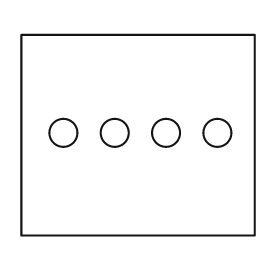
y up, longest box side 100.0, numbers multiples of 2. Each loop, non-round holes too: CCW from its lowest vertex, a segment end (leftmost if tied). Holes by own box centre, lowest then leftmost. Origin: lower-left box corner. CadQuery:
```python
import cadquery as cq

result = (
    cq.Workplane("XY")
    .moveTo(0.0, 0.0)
    .lineTo(100.0, 0.0)
    .lineTo(100.0, 86.0)
    .lineTo(0.0, 86.0)
    .close()
    .moveTo(18.0, 44.0)
    .circle(6.0)
    .moveTo(40.0, 44.0)
    .circle(6.0)
    .moveTo(62.0, 44.0)
    .circle(6.0)
    .moveTo(84.0, 44.0)
    .circle(6.0)
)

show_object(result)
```